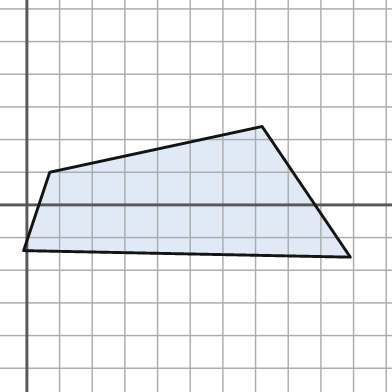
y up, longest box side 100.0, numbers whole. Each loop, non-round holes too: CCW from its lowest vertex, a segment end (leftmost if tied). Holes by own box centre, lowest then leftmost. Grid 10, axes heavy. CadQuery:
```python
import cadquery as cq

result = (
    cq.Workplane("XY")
    .moveTo(99.0, -16.0)
    .lineTo(72.0, 24.0)
    .lineTo(7.0, 10.0)
    .lineTo(-1.0, -14.0)
    .close()
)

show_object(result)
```